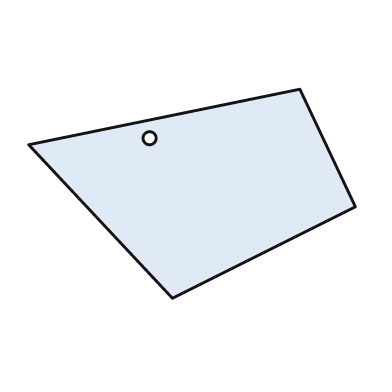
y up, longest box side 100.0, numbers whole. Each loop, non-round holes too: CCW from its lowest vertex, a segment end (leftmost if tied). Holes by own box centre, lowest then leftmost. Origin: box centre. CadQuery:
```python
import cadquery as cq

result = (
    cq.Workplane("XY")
    .moveTo(-6.0, -32.0)
    .lineTo(50.0, -4.0)
    .lineTo(33.0, 32.0)
    .lineTo(-50.0, 15.0)
    .close()
    .moveTo(-13.0, 17.0)
    .circle(2.0)
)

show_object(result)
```